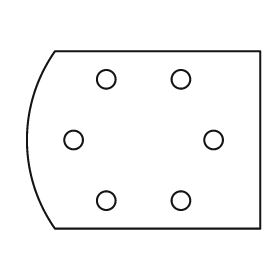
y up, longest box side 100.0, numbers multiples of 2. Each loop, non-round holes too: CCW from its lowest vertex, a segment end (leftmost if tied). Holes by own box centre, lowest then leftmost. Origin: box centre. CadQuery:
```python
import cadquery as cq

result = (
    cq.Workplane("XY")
    .moveTo(-38.0, -38.0)
    .lineTo(50.0, -38.0)
    .lineTo(50.0, 38.0)
    .lineTo(-38.0, 38.0)
    .threePointArc((-50.0, 0.0), (-38.0, -38.0))
    .close()
    .moveTo(-16.0, -26.0)
    .circle(4.0)
    .moveTo(16.0, -26.0)
    .circle(4.0)
    .moveTo(-30.0, 0.0)
    .circle(4.0)
    .moveTo(30.0, 0.0)
    .circle(4.0)
    .moveTo(-16.0, 26.0)
    .circle(4.0)
    .moveTo(16.0, 26.0)
    .circle(4.0)
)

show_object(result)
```